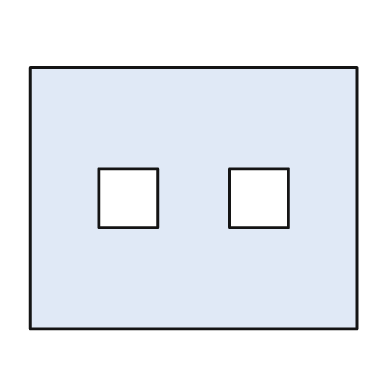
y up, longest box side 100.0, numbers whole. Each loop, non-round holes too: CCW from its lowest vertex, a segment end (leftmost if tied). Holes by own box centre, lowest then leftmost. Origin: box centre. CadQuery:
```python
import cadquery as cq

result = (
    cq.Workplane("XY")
    .moveTo(-50.0, -40.0)
    .lineTo(50.0, -40.0)
    .lineTo(50.0, 40.0)
    .lineTo(-50.0, 40.0)
    .close()
    .moveTo(-29.0, -9.0)
    .lineTo(-11.0, -9.0)
    .lineTo(-11.0, 9.0)
    .lineTo(-29.0, 9.0)
    .close()
    .moveTo(11.0, -9.0)
    .lineTo(29.0, -9.0)
    .lineTo(29.0, 9.0)
    .lineTo(11.0, 9.0)
    .close()
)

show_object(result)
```